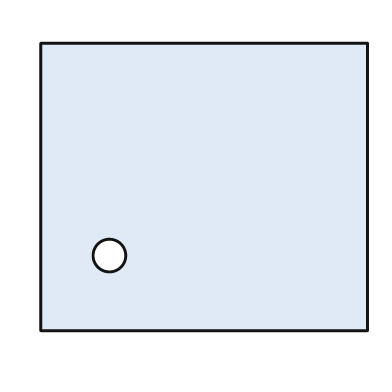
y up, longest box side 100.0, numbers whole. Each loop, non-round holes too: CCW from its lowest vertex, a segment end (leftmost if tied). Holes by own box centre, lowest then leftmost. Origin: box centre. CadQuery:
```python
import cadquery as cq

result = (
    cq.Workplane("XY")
    .moveTo(-50.0, -44.0)
    .lineTo(50.0, -44.0)
    .lineTo(50.0, 44.0)
    .lineTo(-50.0, 44.0)
    .close()
    .moveTo(-29.0, -21.0)
    .circle(5.0)
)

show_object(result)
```